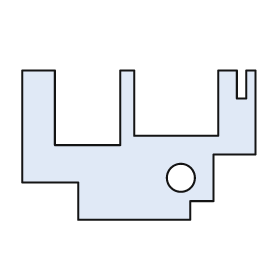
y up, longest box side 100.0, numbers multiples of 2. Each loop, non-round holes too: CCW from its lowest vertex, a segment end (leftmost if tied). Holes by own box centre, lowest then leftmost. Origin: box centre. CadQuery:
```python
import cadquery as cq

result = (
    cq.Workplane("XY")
    .moveTo(-26.0, -32.0)
    .lineTo(22.0, -32.0)
    .lineTo(22.0, -24.0)
    .lineTo(32.0, -24.0)
    .lineTo(32.0, -4.0)
    .lineTo(50.0, -4.0)
    .lineTo(50.0, 32.0)
    .lineTo(46.0, 32.0)
    .lineTo(46.0, 20.0)
    .lineTo(42.0, 20.0)
    .lineTo(42.0, 32.0)
    .lineTo(34.0, 32.0)
    .lineTo(34.0, 4.0)
    .lineTo(-2.0, 4.0)
    .lineTo(-2.0, 32.0)
    .lineTo(-8.0, 32.0)
    .lineTo(-8.0, 0.0)
    .lineTo(-36.0, 0.0)
    .lineTo(-36.0, 32.0)
    .lineTo(-50.0, 32.0)
    .lineTo(-50.0, -16.0)
    .lineTo(-26.0, -16.0)
    .close()
    .moveTo(18.0, -14.0)
    .circle(6.0)
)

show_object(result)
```